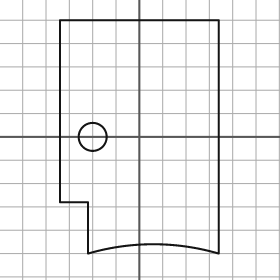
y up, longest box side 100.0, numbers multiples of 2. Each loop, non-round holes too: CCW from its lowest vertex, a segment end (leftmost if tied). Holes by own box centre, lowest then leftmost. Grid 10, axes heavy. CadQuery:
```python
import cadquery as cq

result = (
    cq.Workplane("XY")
    .moveTo(-22.0, -50.0)
    .threePointArc((6.0, -46.0), (34.0, -50.0))
    .lineTo(34.0, 50.0)
    .lineTo(-34.0, 50.0)
    .lineTo(-34.0, -28.0)
    .lineTo(-22.0, -28.0)
    .close()
    .moveTo(-20.0, 0.0)
    .circle(6.0)
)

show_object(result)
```